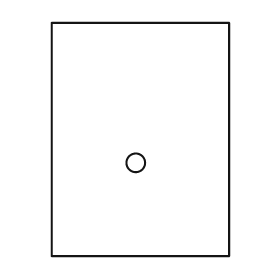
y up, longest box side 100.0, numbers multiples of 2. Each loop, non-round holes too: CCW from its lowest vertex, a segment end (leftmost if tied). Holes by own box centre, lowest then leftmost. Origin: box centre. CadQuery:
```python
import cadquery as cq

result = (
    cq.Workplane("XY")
    .moveTo(-38.0, -50.0)
    .lineTo(38.0, -50.0)
    .lineTo(38.0, 50.0)
    .lineTo(-38.0, 50.0)
    .close()
    .moveTo(-2.0, -10.0)
    .circle(4.0)
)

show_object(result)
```